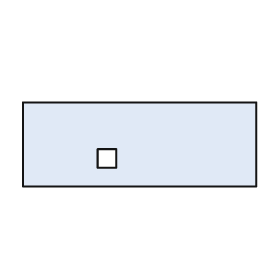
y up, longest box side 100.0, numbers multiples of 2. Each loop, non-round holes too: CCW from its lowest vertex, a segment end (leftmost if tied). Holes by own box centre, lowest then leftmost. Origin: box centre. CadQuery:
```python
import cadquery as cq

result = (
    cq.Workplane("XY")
    .moveTo(-50.0, -18.0)
    .lineTo(50.0, -18.0)
    .lineTo(50.0, 18.0)
    .lineTo(-50.0, 18.0)
    .close()
    .moveTo(-18.0, -10.0)
    .lineTo(-10.0, -10.0)
    .lineTo(-10.0, -2.0)
    .lineTo(-18.0, -2.0)
    .close()
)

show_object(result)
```